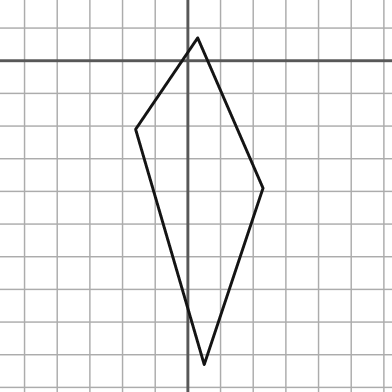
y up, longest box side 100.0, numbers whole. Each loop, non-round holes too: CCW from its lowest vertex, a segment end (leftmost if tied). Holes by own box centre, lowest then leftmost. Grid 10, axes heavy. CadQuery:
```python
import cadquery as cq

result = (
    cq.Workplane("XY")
    .moveTo(5.0, -93.0)
    .lineTo(23.0, -39.0)
    .lineTo(3.0, 7.0)
    .lineTo(-16.0, -21.0)
    .close()
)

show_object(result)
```